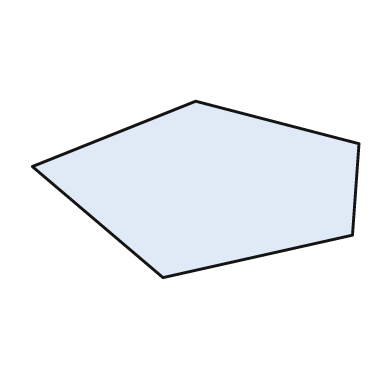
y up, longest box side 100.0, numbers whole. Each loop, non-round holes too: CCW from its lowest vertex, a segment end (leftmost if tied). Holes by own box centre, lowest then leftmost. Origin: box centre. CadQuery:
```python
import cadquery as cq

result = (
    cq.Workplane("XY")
    .moveTo(-10.0, -27.0)
    .lineTo(48.0, -14.0)
    .lineTo(50.0, 14.0)
    .lineTo(0.0, 27.0)
    .lineTo(-50.0, 7.0)
    .close()
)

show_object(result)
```